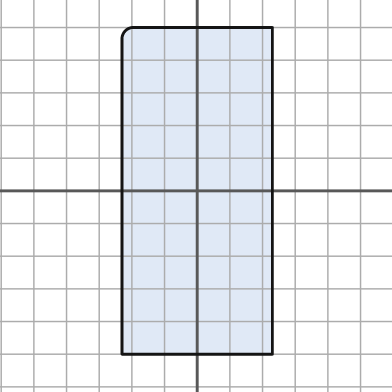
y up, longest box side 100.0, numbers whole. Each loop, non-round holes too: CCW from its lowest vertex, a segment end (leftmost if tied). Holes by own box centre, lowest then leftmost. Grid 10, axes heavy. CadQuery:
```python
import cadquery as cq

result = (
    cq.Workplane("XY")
    .moveTo(-23.0, -50.0)
    .lineTo(23.0, -50.0)
    .lineTo(23.0, 50.0)
    .lineTo(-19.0, 50.0)
    .threePointArc((-22.0, 49.0), (-23.0, 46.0))
    .close()
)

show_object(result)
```